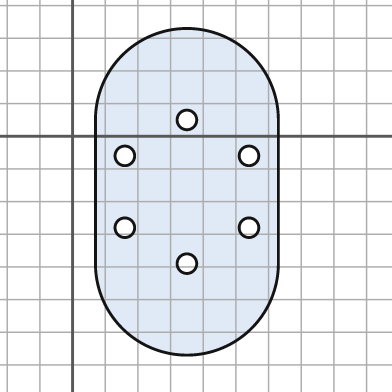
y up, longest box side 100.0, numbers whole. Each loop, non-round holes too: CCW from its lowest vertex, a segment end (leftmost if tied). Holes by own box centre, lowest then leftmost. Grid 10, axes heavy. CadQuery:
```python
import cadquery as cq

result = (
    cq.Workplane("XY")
    .moveTo(7.0, -39.0)
    .threePointArc((35.0, -67.0), (63.0, -39.0))
    .lineTo(63.0, 5.0)
    .threePointArc((35.0, 33.0), (7.0, 5.0))
    .close()
    .moveTo(35.0, -39.0)
    .circle(3.0)
    .moveTo(16.0, -28.0)
    .circle(3.0)
    .moveTo(54.0, -28.0)
    .circle(3.0)
    .moveTo(16.0, -6.0)
    .circle(3.0)
    .moveTo(54.0, -6.0)
    .circle(3.0)
    .moveTo(35.0, 5.0)
    .circle(3.0)
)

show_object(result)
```